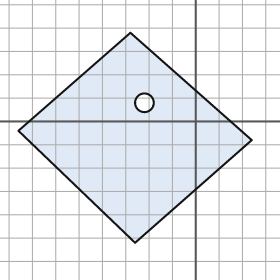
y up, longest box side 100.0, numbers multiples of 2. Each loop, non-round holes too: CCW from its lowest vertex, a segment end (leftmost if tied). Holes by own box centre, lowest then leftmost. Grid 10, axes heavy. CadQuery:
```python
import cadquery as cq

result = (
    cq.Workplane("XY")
    .moveTo(-26.0, -52.0)
    .lineTo(24.0, -8.0)
    .lineTo(-28.0, 38.0)
    .lineTo(-76.0, -4.0)
    .close()
    .moveTo(-22.0, 8.0)
    .circle(4.0)
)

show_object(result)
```